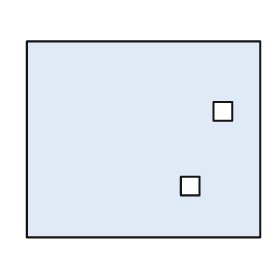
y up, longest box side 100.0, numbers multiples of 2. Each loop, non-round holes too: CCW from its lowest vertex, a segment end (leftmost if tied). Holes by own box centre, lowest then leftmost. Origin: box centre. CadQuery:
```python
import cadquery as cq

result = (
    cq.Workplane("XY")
    .moveTo(-50.0, -42.0)
    .lineTo(50.0, -42.0)
    .lineTo(50.0, 42.0)
    .lineTo(-50.0, 42.0)
    .close()
    .moveTo(16.0, -24.0)
    .lineTo(24.0, -24.0)
    .lineTo(24.0, -16.0)
    .lineTo(16.0, -16.0)
    .close()
    .moveTo(30.0, 8.0)
    .lineTo(38.0, 8.0)
    .lineTo(38.0, 16.0)
    .lineTo(30.0, 16.0)
    .close()
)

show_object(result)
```